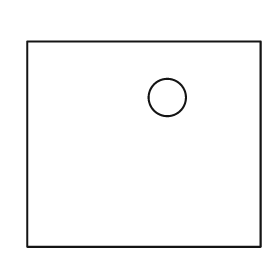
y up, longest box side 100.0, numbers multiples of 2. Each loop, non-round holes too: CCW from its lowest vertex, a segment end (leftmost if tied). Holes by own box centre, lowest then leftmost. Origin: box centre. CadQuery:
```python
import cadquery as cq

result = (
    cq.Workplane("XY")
    .moveTo(-50.0, -44.0)
    .lineTo(50.0, -44.0)
    .lineTo(50.0, 44.0)
    .lineTo(-50.0, 44.0)
    .close()
    .moveTo(10.0, 20.0)
    .circle(8.0)
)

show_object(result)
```